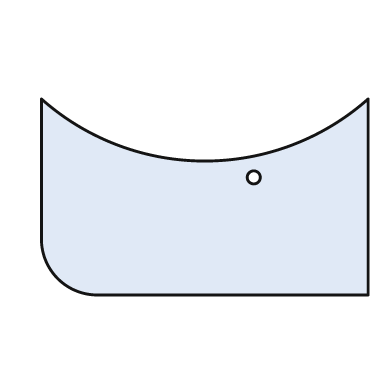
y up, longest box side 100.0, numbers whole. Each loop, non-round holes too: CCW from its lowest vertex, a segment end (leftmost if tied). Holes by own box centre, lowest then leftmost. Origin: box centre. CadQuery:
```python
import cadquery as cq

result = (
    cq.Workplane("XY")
    .moveTo(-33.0, -30.0)
    .lineTo(50.0, -30.0)
    .lineTo(50.0, 30.0)
    .threePointArc((0.0, 11.0), (-50.0, 30.0))
    .lineTo(-50.0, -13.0)
    .threePointArc((-45.0, -25.0), (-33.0, -30.0))
    .close()
    .moveTo(15.0, 6.0)
    .circle(2.0)
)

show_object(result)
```